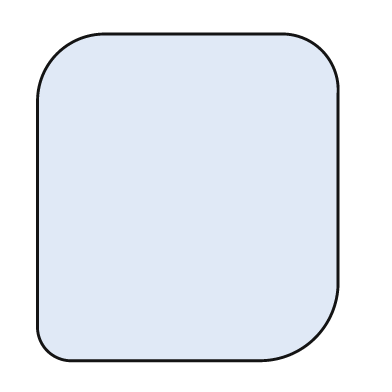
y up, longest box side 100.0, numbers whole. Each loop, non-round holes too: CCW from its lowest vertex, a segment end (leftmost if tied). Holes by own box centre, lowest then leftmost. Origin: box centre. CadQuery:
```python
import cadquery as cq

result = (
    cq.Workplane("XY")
    .moveTo(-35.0, -50.0)
    .lineTo(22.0, -50.0)
    .threePointArc((39.0, -43.0), (46.0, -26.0))
    .lineTo(46.0, 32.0)
    .threePointArc((41.0, 45.0), (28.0, 50.0))
    .lineTo(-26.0, 50.0)
    .threePointArc((-40.0, 44.0), (-46.0, 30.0))
    .lineTo(-46.0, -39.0)
    .threePointArc((-43.0, -47.0), (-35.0, -50.0))
    .close()
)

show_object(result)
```